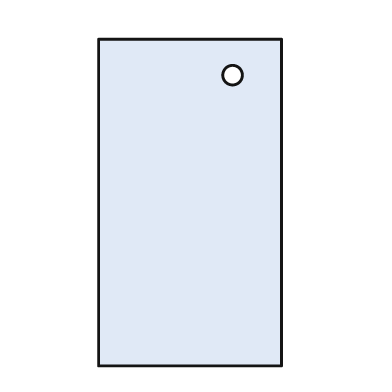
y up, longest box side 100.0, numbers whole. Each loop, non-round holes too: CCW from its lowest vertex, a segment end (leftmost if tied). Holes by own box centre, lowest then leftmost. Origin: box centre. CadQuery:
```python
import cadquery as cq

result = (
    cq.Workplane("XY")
    .moveTo(-28.0, -50.0)
    .lineTo(28.0, -50.0)
    .lineTo(28.0, 50.0)
    .lineTo(-28.0, 50.0)
    .close()
    .moveTo(13.0, 39.0)
    .circle(3.0)
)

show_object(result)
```